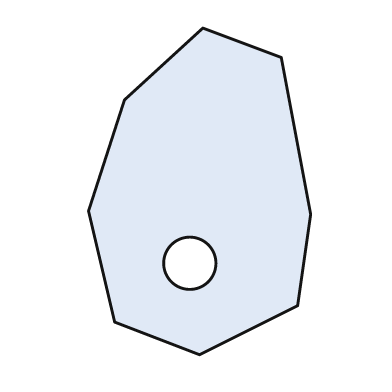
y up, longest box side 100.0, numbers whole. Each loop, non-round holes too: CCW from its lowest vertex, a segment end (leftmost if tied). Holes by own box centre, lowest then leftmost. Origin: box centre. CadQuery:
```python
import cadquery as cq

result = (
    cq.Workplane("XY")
    .moveTo(0.0, -50.0)
    .lineTo(30.0, -35.0)
    .lineTo(34.0, -7.0)
    .lineTo(25.0, 41.0)
    .lineTo(1.0, 50.0)
    .lineTo(-23.0, 28.0)
    .lineTo(-34.0, -6.0)
    .lineTo(-26.0, -40.0)
    .close()
    .moveTo(-3.0, -22.0)
    .circle(8.0)
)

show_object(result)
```